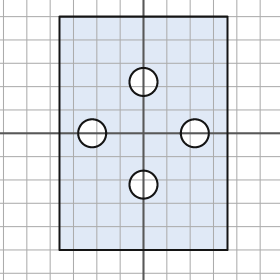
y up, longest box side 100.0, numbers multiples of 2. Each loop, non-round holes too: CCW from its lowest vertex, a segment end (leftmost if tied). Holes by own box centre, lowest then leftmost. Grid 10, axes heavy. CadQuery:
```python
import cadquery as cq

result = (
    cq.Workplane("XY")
    .moveTo(-36.0, -50.0)
    .lineTo(36.0, -50.0)
    .lineTo(36.0, 50.0)
    .lineTo(-36.0, 50.0)
    .close()
    .moveTo(0.0, -22.0)
    .circle(6.0)
    .moveTo(-22.0, 0.0)
    .circle(6.0)
    .moveTo(22.0, 0.0)
    .circle(6.0)
    .moveTo(0.0, 22.0)
    .circle(6.0)
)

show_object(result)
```